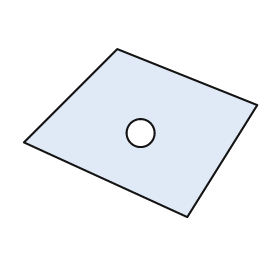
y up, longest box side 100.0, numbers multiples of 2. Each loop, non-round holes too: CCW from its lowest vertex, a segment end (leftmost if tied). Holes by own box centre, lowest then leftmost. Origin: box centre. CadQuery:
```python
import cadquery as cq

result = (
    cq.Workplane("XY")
    .moveTo(20.0, -36.0)
    .lineTo(50.0, 12.0)
    .lineTo(-10.0, 36.0)
    .lineTo(-50.0, -4.0)
    .close()
    .moveTo(0.0, 0.0)
    .circle(6.0)
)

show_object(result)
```